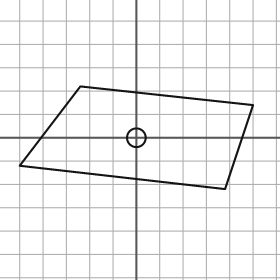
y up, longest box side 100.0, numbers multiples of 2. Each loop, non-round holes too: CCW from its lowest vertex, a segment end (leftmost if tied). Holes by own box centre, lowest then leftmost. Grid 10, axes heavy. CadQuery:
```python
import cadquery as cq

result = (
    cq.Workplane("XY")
    .moveTo(38.0, -22.0)
    .lineTo(50.0, 14.0)
    .lineTo(-24.0, 22.0)
    .lineTo(-50.0, -12.0)
    .close()
    .moveTo(0.0, 0.0)
    .circle(4.0)
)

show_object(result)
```